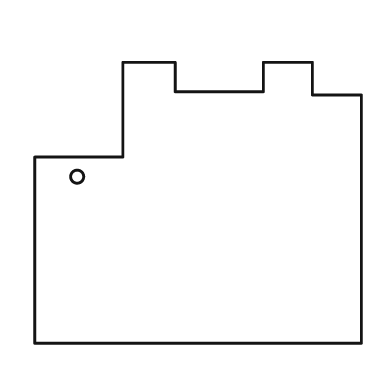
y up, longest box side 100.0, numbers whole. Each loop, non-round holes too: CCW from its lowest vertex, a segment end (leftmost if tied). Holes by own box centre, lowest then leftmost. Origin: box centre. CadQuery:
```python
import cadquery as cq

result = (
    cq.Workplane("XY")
    .moveTo(-50.0, -43.0)
    .lineTo(50.0, -43.0)
    .lineTo(50.0, 33.0)
    .lineTo(35.0, 33.0)
    .lineTo(35.0, 43.0)
    .lineTo(20.0, 43.0)
    .lineTo(20.0, 34.0)
    .lineTo(-7.0, 34.0)
    .lineTo(-7.0, 43.0)
    .lineTo(-23.0, 43.0)
    .lineTo(-23.0, 14.0)
    .lineTo(-50.0, 14.0)
    .close()
    .moveTo(-37.0, 8.0)
    .circle(2.0)
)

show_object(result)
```